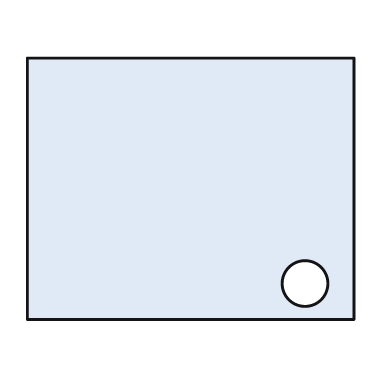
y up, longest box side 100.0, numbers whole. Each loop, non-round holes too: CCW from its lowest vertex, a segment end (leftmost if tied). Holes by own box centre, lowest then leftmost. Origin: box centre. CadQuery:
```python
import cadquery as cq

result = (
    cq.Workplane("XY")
    .moveTo(-50.0, -40.0)
    .lineTo(50.0, -40.0)
    .lineTo(50.0, 40.0)
    .lineTo(-50.0, 40.0)
    .close()
    .moveTo(35.0, -29.0)
    .circle(7.0)
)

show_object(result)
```